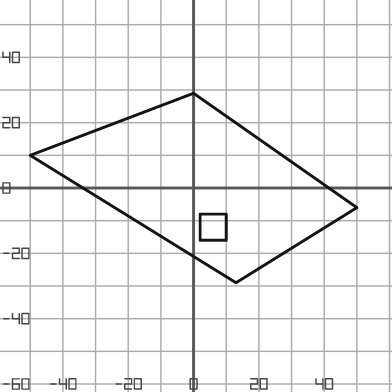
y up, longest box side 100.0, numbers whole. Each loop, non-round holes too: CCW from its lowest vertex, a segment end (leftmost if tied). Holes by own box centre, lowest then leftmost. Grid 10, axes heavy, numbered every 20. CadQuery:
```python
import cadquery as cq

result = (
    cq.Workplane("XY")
    .moveTo(13.0, -29.0)
    .lineTo(50.0, -6.0)
    .lineTo(0.0, 29.0)
    .lineTo(-50.0, 10.0)
    .close()
    .moveTo(2.0, -16.0)
    .lineTo(10.0, -16.0)
    .lineTo(10.0, -8.0)
    .lineTo(2.0, -8.0)
    .close()
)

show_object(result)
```